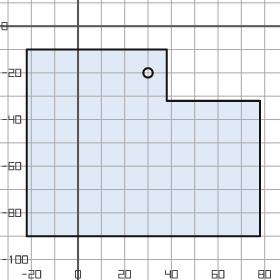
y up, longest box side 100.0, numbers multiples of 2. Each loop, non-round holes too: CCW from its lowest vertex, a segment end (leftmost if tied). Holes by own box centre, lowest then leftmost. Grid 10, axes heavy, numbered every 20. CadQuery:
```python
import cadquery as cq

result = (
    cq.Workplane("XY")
    .moveTo(-22.0, -90.0)
    .lineTo(78.0, -90.0)
    .lineTo(78.0, -32.0)
    .lineTo(38.0, -32.0)
    .lineTo(38.0, -10.0)
    .lineTo(-22.0, -10.0)
    .close()
    .moveTo(30.0, -20.0)
    .circle(2.0)
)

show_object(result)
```